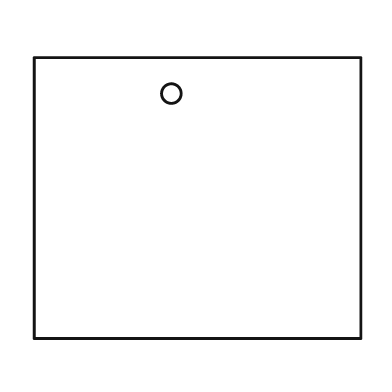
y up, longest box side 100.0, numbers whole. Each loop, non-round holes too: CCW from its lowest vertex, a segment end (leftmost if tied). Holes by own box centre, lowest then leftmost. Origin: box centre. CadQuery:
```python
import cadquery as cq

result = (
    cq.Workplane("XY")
    .moveTo(-50.0, -43.0)
    .lineTo(50.0, -43.0)
    .lineTo(50.0, 43.0)
    .lineTo(-50.0, 43.0)
    .close()
    .moveTo(-8.0, 32.0)
    .circle(3.0)
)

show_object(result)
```